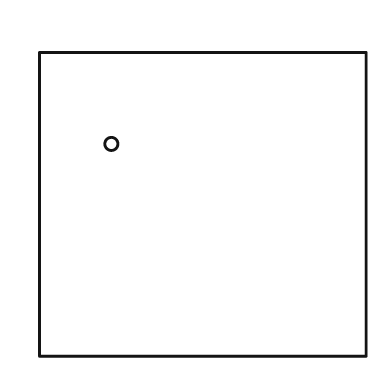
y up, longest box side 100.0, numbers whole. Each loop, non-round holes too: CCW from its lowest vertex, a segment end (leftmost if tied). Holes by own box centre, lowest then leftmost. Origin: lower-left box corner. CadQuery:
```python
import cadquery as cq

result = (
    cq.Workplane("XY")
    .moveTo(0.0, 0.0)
    .lineTo(100.0, 0.0)
    .lineTo(100.0, 93.0)
    .lineTo(0.0, 93.0)
    .close()
    .moveTo(22.0, 65.0)
    .circle(2.0)
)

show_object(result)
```